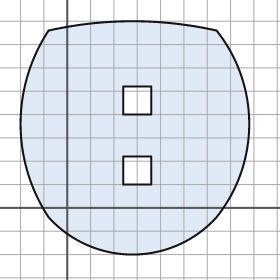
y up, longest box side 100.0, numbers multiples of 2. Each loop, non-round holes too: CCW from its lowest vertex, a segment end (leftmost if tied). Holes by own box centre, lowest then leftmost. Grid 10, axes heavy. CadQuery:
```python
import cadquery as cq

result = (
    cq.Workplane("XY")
    .moveTo(-8.0, -4.0)
    .threePointArc((28.0, -20.0), (64.0, -4.0))
    .threePointArc((78.0, 36.0), (64.0, 76.0))
    .threePointArc((28.0, 80.0), (-8.0, 76.0))
    .threePointArc((-20.0, 36.0), (-8.0, -4.0))
    .close()
    .moveTo(24.0, 10.0)
    .lineTo(36.0, 10.0)
    .lineTo(36.0, 22.0)
    .lineTo(24.0, 22.0)
    .close()
    .moveTo(24.0, 40.0)
    .lineTo(36.0, 40.0)
    .lineTo(36.0, 52.0)
    .lineTo(24.0, 52.0)
    .close()
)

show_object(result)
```